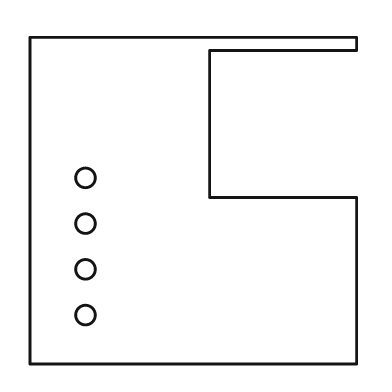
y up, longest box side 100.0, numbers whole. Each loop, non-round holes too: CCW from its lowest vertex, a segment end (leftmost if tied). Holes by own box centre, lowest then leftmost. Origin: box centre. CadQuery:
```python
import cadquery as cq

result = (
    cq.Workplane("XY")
    .moveTo(-50.0, -50.0)
    .lineTo(50.0, -50.0)
    .lineTo(50.0, 1.0)
    .lineTo(5.0, 1.0)
    .lineTo(5.0, 46.0)
    .lineTo(50.0, 46.0)
    .lineTo(50.0, 50.0)
    .lineTo(-50.0, 50.0)
    .close()
    .moveTo(-33.0, -35.0)
    .circle(3.0)
    .moveTo(-33.0, -21.0)
    .circle(3.0)
    .moveTo(-33.0, -7.0)
    .circle(3.0)
    .moveTo(-33.0, 7.0)
    .circle(3.0)
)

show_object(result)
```